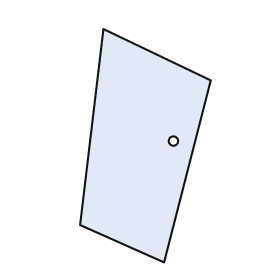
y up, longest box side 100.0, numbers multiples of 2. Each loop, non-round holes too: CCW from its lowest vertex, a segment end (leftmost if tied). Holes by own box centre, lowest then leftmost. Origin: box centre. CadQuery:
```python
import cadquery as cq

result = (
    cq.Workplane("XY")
    .moveTo(8.0, -50.0)
    .lineTo(28.0, 28.0)
    .lineTo(-18.0, 50.0)
    .lineTo(-28.0, -34.0)
    .close()
    .moveTo(12.0, 2.0)
    .circle(2.0)
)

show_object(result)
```